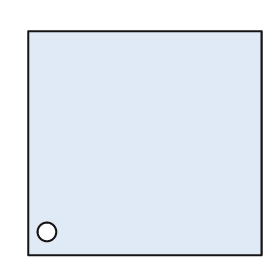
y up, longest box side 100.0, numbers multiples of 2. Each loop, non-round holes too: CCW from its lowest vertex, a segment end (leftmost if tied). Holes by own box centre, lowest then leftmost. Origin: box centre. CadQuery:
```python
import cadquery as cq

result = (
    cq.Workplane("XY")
    .moveTo(-50.0, -48.0)
    .lineTo(50.0, -48.0)
    .lineTo(50.0, 48.0)
    .lineTo(-50.0, 48.0)
    .close()
    .moveTo(-42.0, -38.0)
    .circle(4.0)
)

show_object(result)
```